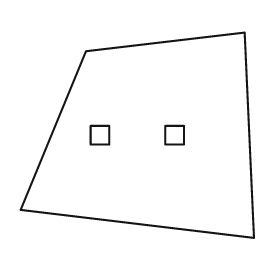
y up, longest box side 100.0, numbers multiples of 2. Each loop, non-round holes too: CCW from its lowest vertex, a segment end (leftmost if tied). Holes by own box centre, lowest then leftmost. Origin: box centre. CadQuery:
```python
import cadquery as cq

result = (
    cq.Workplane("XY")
    .moveTo(50.0, -44.0)
    .lineTo(46.0, 44.0)
    .lineTo(-22.0, 36.0)
    .lineTo(-50.0, -32.0)
    .close()
    .moveTo(-20.0, -4.0)
    .lineTo(-12.0, -4.0)
    .lineTo(-12.0, 4.0)
    .lineTo(-20.0, 4.0)
    .close()
    .moveTo(12.0, -4.0)
    .lineTo(20.0, -4.0)
    .lineTo(20.0, 4.0)
    .lineTo(12.0, 4.0)
    .close()
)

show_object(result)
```